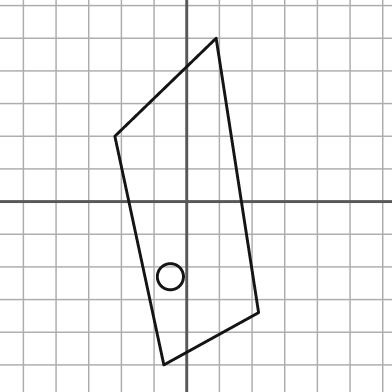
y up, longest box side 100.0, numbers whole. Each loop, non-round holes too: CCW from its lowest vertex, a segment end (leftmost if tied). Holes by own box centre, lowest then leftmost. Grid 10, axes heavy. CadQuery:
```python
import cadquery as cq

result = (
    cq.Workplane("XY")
    .moveTo(-7.0, -50.0)
    .lineTo(22.0, -34.0)
    .lineTo(9.0, 50.0)
    .lineTo(-22.0, 20.0)
    .close()
    .moveTo(-5.0, -23.0)
    .circle(4.0)
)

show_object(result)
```